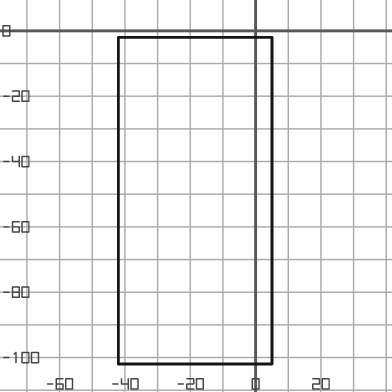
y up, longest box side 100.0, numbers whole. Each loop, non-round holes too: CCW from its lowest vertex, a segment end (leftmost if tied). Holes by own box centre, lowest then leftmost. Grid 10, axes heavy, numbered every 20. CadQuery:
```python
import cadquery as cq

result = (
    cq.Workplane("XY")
    .moveTo(-42.0, -102.0)
    .lineTo(5.0, -102.0)
    .lineTo(5.0, -2.0)
    .lineTo(-42.0, -2.0)
    .close()
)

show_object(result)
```